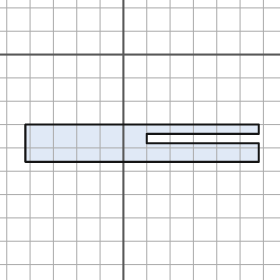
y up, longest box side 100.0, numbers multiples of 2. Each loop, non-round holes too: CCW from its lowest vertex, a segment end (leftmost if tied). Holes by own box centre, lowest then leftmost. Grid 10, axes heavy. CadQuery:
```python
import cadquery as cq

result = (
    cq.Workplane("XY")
    .moveTo(-42.0, -46.0)
    .lineTo(58.0, -46.0)
    .lineTo(58.0, -38.0)
    .lineTo(10.0, -38.0)
    .lineTo(10.0, -34.0)
    .lineTo(58.0, -34.0)
    .lineTo(58.0, -30.0)
    .lineTo(-42.0, -30.0)
    .close()
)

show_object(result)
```